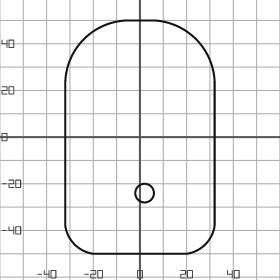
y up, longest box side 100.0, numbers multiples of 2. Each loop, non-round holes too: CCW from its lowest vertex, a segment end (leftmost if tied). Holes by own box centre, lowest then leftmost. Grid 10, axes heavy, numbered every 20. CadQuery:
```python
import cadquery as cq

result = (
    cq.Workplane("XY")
    .moveTo(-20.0, -50.0)
    .lineTo(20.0, -50.0)
    .threePointArc((28.0, -46.0), (32.0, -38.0))
    .lineTo(32.0, 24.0)
    .threePointArc((24.0, 42.0), (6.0, 50.0))
    .lineTo(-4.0, 50.0)
    .threePointArc((-24.0, 42.0), (-32.0, 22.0))
    .lineTo(-32.0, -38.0)
    .threePointArc((-28.0, -46.0), (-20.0, -50.0))
    .close()
    .moveTo(2.0, -24.0)
    .circle(4.0)
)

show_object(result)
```